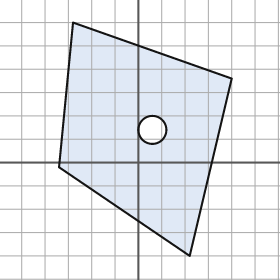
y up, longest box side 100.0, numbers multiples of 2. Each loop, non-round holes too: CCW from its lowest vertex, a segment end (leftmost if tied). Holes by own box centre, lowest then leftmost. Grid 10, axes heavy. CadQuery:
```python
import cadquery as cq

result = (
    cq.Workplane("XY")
    .moveTo(22.0, -40.0)
    .lineTo(40.0, 36.0)
    .lineTo(-28.0, 60.0)
    .lineTo(-34.0, -2.0)
    .close()
    .moveTo(6.0, 14.0)
    .circle(6.0)
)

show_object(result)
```